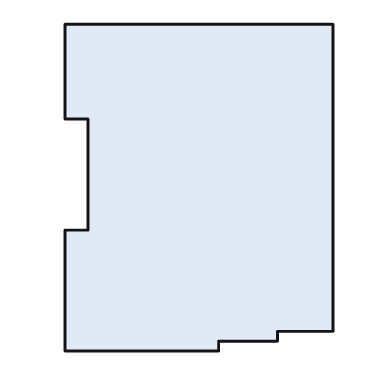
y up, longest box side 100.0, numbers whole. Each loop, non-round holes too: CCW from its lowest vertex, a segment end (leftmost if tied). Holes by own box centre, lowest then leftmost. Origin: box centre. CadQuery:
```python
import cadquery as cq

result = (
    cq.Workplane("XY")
    .moveTo(-41.0, -50.0)
    .lineTo(6.0, -50.0)
    .lineTo(6.0, -47.0)
    .lineTo(24.0, -47.0)
    .lineTo(24.0, -44.0)
    .lineTo(41.0, -44.0)
    .lineTo(41.0, 50.0)
    .lineTo(-41.0, 50.0)
    .lineTo(-41.0, 21.0)
    .lineTo(-34.0, 21.0)
    .lineTo(-34.0, -13.0)
    .lineTo(-41.0, -13.0)
    .close()
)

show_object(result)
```